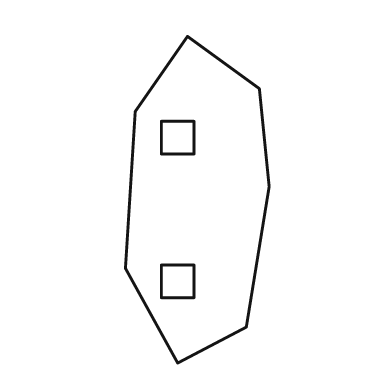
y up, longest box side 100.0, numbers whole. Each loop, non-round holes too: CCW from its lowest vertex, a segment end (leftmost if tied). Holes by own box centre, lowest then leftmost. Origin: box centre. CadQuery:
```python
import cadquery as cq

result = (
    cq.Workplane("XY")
    .moveTo(-6.0, -50.0)
    .lineTo(15.0, -39.0)
    .lineTo(22.0, 4.0)
    .lineTo(19.0, 34.0)
    .lineTo(-3.0, 50.0)
    .lineTo(-19.0, 27.0)
    .lineTo(-22.0, -21.0)
    .close()
    .moveTo(-11.0, -30.0)
    .lineTo(-1.0, -30.0)
    .lineTo(-1.0, -20.0)
    .lineTo(-11.0, -20.0)
    .close()
    .moveTo(-11.0, 14.0)
    .lineTo(-1.0, 14.0)
    .lineTo(-1.0, 24.0)
    .lineTo(-11.0, 24.0)
    .close()
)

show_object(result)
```